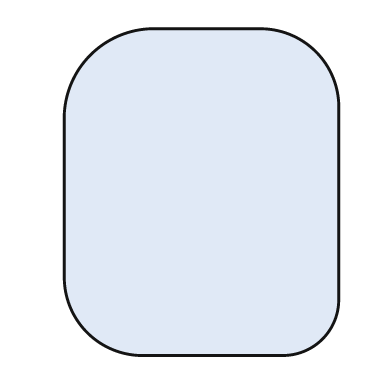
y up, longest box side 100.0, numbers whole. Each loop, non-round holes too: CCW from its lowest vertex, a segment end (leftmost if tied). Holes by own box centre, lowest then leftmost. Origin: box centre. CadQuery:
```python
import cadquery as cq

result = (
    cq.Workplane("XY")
    .moveTo(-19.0, -50.0)
    .lineTo(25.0, -50.0)
    .threePointArc((37.0, -45.0), (42.0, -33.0))
    .lineTo(42.0, 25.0)
    .threePointArc((35.0, 43.0), (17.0, 50.0))
    .lineTo(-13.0, 50.0)
    .threePointArc((-34.0, 42.0), (-42.0, 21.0))
    .lineTo(-42.0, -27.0)
    .threePointArc((-35.0, -43.0), (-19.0, -50.0))
    .close()
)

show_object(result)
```